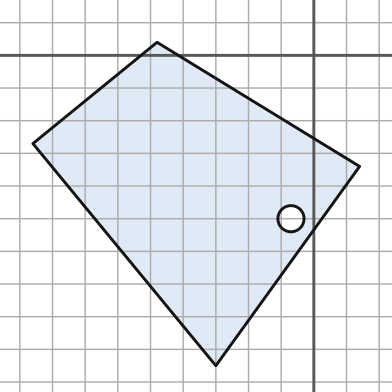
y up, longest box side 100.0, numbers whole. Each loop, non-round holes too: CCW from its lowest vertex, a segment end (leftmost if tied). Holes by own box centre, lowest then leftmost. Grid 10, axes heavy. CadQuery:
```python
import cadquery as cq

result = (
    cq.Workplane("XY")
    .moveTo(-30.0, -95.0)
    .lineTo(14.0, -34.0)
    .lineTo(-48.0, 4.0)
    .lineTo(-86.0, -27.0)
    .close()
    .moveTo(-7.0, -50.0)
    .circle(4.0)
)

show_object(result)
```